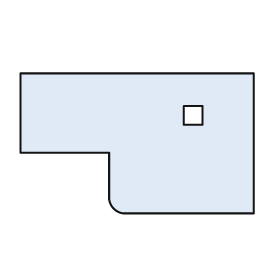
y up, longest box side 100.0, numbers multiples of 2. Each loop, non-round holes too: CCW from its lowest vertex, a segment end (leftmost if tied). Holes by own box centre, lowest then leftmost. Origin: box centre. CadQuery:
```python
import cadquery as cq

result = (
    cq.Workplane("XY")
    .moveTo(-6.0, -30.0)
    .lineTo(50.0, -30.0)
    .lineTo(50.0, 30.0)
    .lineTo(-50.0, 30.0)
    .lineTo(-50.0, -4.0)
    .lineTo(-12.0, -4.0)
    .lineTo(-12.0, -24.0)
    .threePointArc((-10.0, -28.0), (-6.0, -30.0))
    .close()
    .moveTo(20.0, 8.0)
    .lineTo(28.0, 8.0)
    .lineTo(28.0, 16.0)
    .lineTo(20.0, 16.0)
    .close()
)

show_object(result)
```